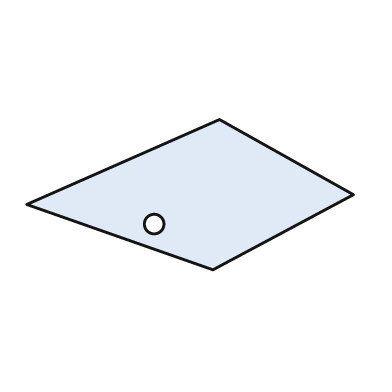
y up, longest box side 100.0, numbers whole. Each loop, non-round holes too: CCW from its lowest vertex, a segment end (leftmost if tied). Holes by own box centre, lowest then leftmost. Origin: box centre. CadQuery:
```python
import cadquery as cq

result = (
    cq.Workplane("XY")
    .moveTo(7.0, -23.0)
    .lineTo(50.0, 0.0)
    .lineTo(9.0, 23.0)
    .lineTo(-50.0, -3.0)
    .close()
    .moveTo(-11.0, -9.0)
    .circle(3.0)
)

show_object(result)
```